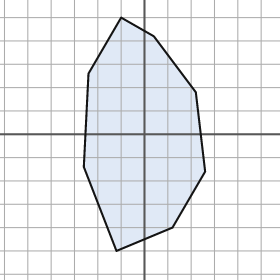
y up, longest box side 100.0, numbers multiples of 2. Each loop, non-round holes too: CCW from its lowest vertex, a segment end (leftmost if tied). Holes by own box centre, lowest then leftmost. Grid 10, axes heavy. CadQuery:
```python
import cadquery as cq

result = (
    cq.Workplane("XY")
    .moveTo(-12.0, -50.0)
    .lineTo(12.0, -40.0)
    .lineTo(26.0, -16.0)
    .lineTo(22.0, 18.0)
    .lineTo(4.0, 42.0)
    .lineTo(-10.0, 50.0)
    .lineTo(-24.0, 26.0)
    .lineTo(-26.0, -14.0)
    .close()
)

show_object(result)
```